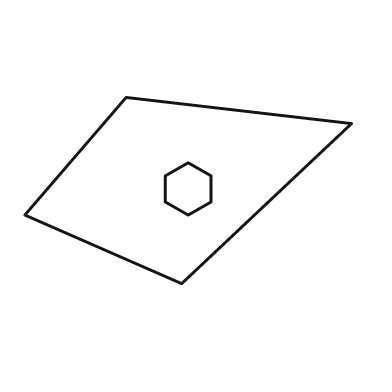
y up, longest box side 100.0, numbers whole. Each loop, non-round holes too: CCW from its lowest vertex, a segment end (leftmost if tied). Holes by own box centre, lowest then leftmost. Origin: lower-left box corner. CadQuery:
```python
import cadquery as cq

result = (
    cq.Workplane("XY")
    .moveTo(48.0, 0.0)
    .lineTo(100.0, 49.0)
    .lineTo(31.0, 57.0)
    .lineTo(0.0, 21.0)
    .close()
    .moveTo(50.0, 21.0)
    .lineTo(57.0, 25.0)
    .lineTo(57.0, 33.0)
    .lineTo(50.0, 37.0)
    .lineTo(43.0, 33.0)
    .lineTo(43.0, 25.0)
    .close()
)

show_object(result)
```